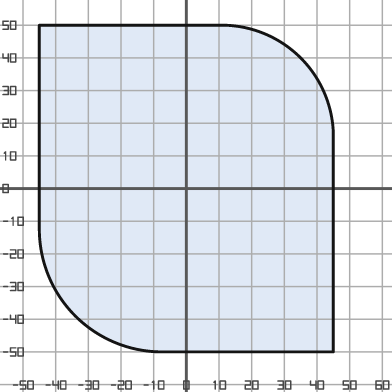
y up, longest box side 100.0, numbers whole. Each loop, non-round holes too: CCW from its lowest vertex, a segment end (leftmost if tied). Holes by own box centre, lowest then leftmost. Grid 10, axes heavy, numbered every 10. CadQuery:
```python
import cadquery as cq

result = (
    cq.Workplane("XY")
    .moveTo(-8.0, -50.0)
    .lineTo(45.0, -50.0)
    .lineTo(45.0, 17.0)
    .threePointArc((35.0, 40.0), (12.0, 50.0))
    .lineTo(-45.0, 50.0)
    .lineTo(-45.0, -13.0)
    .threePointArc((-34.0, -39.0), (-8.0, -50.0))
    .close()
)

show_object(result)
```